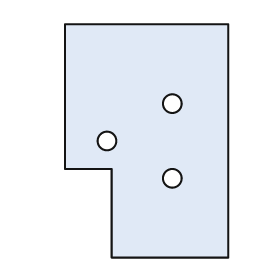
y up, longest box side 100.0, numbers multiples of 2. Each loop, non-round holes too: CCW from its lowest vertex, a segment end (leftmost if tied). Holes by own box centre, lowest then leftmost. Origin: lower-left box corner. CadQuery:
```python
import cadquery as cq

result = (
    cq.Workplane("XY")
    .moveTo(20.0, 0.0)
    .lineTo(70.0, 0.0)
    .lineTo(70.0, 100.0)
    .lineTo(0.0, 100.0)
    .lineTo(0.0, 38.0)
    .lineTo(20.0, 38.0)
    .close()
    .moveTo(46.0, 34.0)
    .circle(4.0)
    .moveTo(18.0, 50.0)
    .circle(4.0)
    .moveTo(46.0, 66.0)
    .circle(4.0)
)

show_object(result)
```